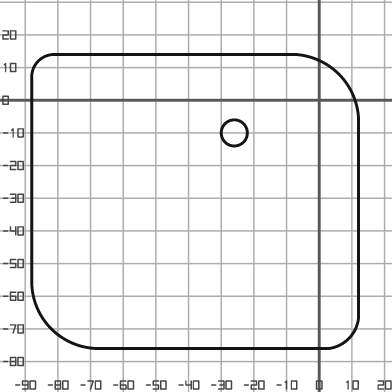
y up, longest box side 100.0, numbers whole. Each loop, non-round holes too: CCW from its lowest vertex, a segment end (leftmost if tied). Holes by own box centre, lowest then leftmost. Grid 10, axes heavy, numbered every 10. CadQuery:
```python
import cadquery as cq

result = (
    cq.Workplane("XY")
    .moveTo(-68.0, -76.0)
    .lineTo(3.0, -76.0)
    .threePointArc((9.0, -73.0), (12.0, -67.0))
    .lineTo(12.0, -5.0)
    .threePointArc((6.0, 8.0), (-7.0, 14.0))
    .lineTo(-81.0, 14.0)
    .threePointArc((-86.0, 12.0), (-88.0, 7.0))
    .lineTo(-88.0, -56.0)
    .threePointArc((-82.0, -70.0), (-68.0, -76.0))
    .close()
    .moveTo(-26.0, -10.0)
    .circle(4.0)
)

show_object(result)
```